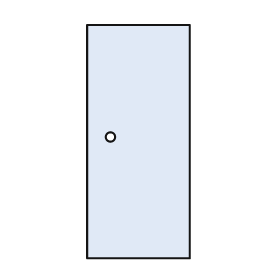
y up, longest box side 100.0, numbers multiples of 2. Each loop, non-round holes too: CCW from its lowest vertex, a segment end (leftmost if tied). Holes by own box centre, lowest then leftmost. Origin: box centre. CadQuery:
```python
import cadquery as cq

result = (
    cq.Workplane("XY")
    .moveTo(-22.0, -50.0)
    .lineTo(22.0, -50.0)
    .lineTo(22.0, 50.0)
    .lineTo(-22.0, 50.0)
    .close()
    .moveTo(-12.0, 2.0)
    .circle(2.0)
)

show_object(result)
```